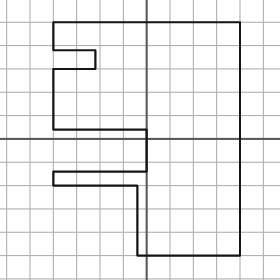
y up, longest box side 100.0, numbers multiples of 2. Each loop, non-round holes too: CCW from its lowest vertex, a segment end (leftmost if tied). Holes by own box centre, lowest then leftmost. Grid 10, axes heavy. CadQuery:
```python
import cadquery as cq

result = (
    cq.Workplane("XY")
    .moveTo(-4.0, -50.0)
    .lineTo(40.0, -50.0)
    .lineTo(40.0, 50.0)
    .lineTo(-40.0, 50.0)
    .lineTo(-40.0, 38.0)
    .lineTo(-22.0, 38.0)
    .lineTo(-22.0, 30.0)
    .lineTo(-40.0, 30.0)
    .lineTo(-40.0, 4.0)
    .lineTo(0.0, 4.0)
    .lineTo(0.0, -14.0)
    .lineTo(-40.0, -14.0)
    .lineTo(-40.0, -20.0)
    .lineTo(-4.0, -20.0)
    .close()
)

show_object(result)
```